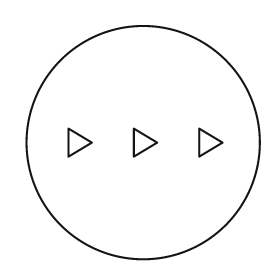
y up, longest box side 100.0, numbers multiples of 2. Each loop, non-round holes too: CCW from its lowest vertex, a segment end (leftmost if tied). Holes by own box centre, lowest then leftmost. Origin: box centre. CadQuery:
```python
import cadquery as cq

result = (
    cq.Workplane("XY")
    .moveTo(0.0, 0.0)
    .circle(50.0)
    .moveTo(-32.0, -6.0)
    .lineTo(-22.0, 0.0)
    .lineTo(-32.0, 6.0)
    .close()
    .moveTo(-4.0, -6.0)
    .lineTo(6.0, 0.0)
    .lineTo(-4.0, 6.0)
    .close()
    .moveTo(24.0, -6.0)
    .lineTo(34.0, 0.0)
    .lineTo(24.0, 6.0)
    .close()
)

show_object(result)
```